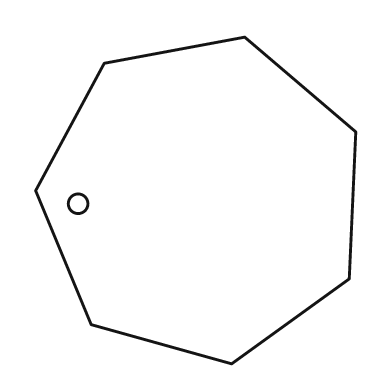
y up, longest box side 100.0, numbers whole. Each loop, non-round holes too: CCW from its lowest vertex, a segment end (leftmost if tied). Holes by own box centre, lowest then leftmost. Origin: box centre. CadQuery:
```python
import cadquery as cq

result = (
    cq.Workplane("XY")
    .moveTo(11.0, -50.0)
    .lineTo(47.0, -24.0)
    .lineTo(49.0, 21.0)
    .lineTo(15.0, 50.0)
    .lineTo(-28.0, 42.0)
    .lineTo(-49.0, 3.0)
    .lineTo(-32.0, -38.0)
    .close()
    .moveTo(-36.0, -1.0)
    .circle(3.0)
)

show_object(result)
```